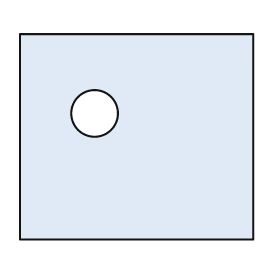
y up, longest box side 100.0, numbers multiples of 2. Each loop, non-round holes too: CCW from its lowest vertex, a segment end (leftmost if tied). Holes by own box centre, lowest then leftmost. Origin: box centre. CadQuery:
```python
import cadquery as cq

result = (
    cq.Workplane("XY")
    .moveTo(-50.0, -44.0)
    .lineTo(50.0, -44.0)
    .lineTo(50.0, 44.0)
    .lineTo(-50.0, 44.0)
    .close()
    .moveTo(-18.0, 10.0)
    .circle(10.0)
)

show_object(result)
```